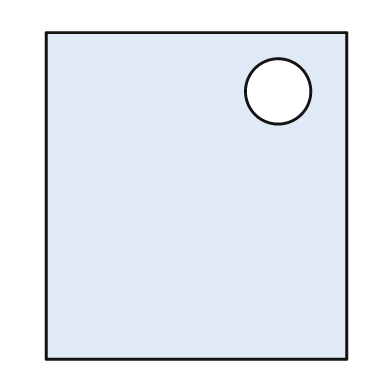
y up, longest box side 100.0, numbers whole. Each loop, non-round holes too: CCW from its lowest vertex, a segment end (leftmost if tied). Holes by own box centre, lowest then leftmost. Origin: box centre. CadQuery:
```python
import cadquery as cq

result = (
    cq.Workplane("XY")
    .moveTo(-46.0, -50.0)
    .lineTo(46.0, -50.0)
    .lineTo(46.0, 50.0)
    .lineTo(-46.0, 50.0)
    .close()
    .moveTo(25.0, 32.0)
    .circle(10.0)
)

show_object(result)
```